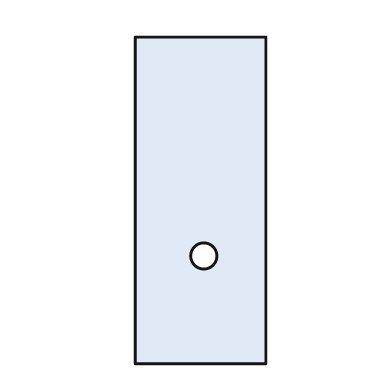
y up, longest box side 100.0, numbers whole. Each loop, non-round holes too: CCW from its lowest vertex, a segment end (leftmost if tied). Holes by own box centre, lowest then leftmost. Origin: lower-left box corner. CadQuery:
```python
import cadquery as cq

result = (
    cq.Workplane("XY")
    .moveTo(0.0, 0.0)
    .lineTo(40.0, 0.0)
    .lineTo(40.0, 100.0)
    .lineTo(0.0, 100.0)
    .close()
    .moveTo(21.0, 33.0)
    .circle(4.0)
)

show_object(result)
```